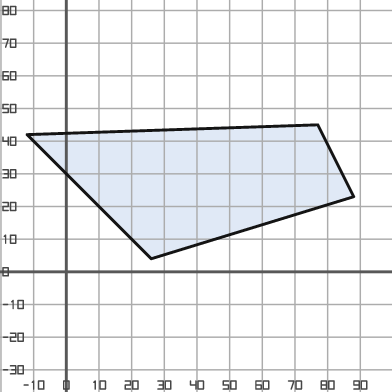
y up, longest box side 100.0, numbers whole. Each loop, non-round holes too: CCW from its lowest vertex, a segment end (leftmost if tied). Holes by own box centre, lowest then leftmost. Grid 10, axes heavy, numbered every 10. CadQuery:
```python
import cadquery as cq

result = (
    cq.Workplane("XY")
    .moveTo(26.0, 4.0)
    .lineTo(88.0, 23.0)
    .lineTo(77.0, 45.0)
    .lineTo(-12.0, 42.0)
    .close()
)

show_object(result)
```